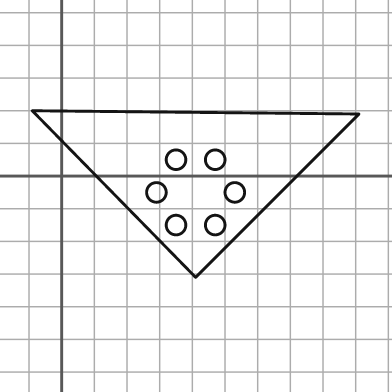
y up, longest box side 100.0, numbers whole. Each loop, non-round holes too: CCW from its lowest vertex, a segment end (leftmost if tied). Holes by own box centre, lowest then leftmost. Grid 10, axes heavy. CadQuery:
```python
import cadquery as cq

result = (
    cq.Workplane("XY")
    .moveTo(41.0, -31.0)
    .lineTo(91.0, 19.0)
    .lineTo(-9.0, 20.0)
    .close()
    .moveTo(35.0, -15.0)
    .circle(3.0)
    .moveTo(47.0, -15.0)
    .circle(3.0)
    .moveTo(29.0, -5.0)
    .circle(3.0)
    .moveTo(53.0, -5.0)
    .circle(3.0)
    .moveTo(35.0, 5.0)
    .circle(3.0)
    .moveTo(47.0, 5.0)
    .circle(3.0)
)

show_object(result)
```